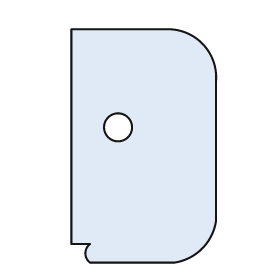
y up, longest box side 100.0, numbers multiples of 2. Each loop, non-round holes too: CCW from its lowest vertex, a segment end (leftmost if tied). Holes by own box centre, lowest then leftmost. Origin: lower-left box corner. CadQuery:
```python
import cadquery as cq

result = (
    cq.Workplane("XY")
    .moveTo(8.0, 0.0)
    .lineTo(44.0, 0.0)
    .threePointArc((56.0, 6.0), (62.0, 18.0))
    .lineTo(62.0, 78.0)
    .threePointArc((56.0, 94.0), (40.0, 100.0))
    .lineTo(0.0, 100.0)
    .lineTo(0.0, 8.0)
    .lineTo(8.0, 8.0)
    .threePointArc((6.0, 4.0), (8.0, 0.0))
    .close()
    .moveTo(20.0, 58.0)
    .circle(6.0)
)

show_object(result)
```